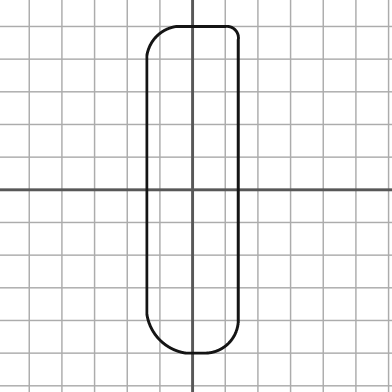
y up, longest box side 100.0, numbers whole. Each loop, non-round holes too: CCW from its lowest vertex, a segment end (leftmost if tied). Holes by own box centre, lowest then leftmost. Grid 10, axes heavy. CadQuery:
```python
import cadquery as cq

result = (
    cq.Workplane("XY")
    .moveTo(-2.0, -50.0)
    .lineTo(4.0, -50.0)
    .threePointArc((11.0, -47.0), (14.0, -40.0))
    .lineTo(14.0, 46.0)
    .threePointArc((13.0, 49.0), (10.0, 50.0))
    .lineTo(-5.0, 50.0)
    .threePointArc((-11.0, 47.0), (-14.0, 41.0))
    .lineTo(-14.0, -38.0)
    .threePointArc((-10.0, -46.0), (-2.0, -50.0))
    .close()
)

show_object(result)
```